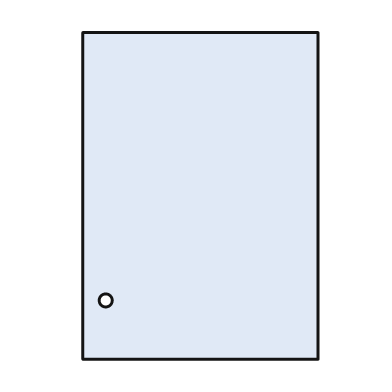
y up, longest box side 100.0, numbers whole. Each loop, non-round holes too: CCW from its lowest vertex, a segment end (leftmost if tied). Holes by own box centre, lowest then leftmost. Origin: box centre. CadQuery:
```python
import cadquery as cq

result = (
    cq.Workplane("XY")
    .moveTo(-36.0, -50.0)
    .lineTo(36.0, -50.0)
    .lineTo(36.0, 50.0)
    .lineTo(-36.0, 50.0)
    .close()
    .moveTo(-29.0, -32.0)
    .circle(2.0)
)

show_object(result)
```